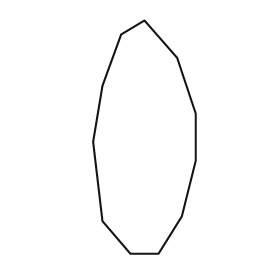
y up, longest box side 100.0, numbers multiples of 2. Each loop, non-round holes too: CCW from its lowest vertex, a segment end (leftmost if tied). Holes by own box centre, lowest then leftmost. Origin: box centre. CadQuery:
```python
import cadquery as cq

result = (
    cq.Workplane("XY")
    .moveTo(-6.0, -50.0)
    .lineTo(6.0, -50.0)
    .lineTo(16.0, -34.0)
    .lineTo(22.0, -10.0)
    .lineTo(22.0, 10.0)
    .lineTo(14.0, 34.0)
    .lineTo(0.0, 50.0)
    .lineTo(-10.0, 44.0)
    .lineTo(-18.0, 22.0)
    .lineTo(-22.0, -2.0)
    .lineTo(-18.0, -36.0)
    .close()
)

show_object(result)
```